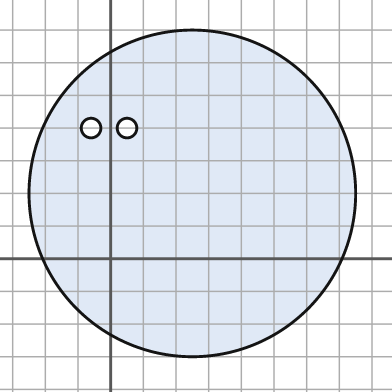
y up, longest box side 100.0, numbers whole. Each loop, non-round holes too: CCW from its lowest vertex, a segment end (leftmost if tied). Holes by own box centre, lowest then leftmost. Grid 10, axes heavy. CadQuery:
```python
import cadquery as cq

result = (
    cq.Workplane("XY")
    .moveTo(25.0, 20.0)
    .circle(50.0)
    .moveTo(-6.0, 40.0)
    .circle(3.0)
    .moveTo(5.0, 40.0)
    .circle(3.0)
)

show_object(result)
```